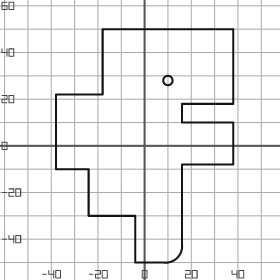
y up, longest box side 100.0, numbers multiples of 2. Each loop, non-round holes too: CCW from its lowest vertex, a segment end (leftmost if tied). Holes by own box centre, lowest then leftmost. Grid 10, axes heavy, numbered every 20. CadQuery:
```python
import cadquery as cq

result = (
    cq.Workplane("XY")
    .moveTo(-4.0, -50.0)
    .lineTo(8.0, -50.0)
    .threePointArc((14.0, -48.0), (16.0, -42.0))
    .lineTo(16.0, -8.0)
    .lineTo(38.0, -8.0)
    .lineTo(38.0, 10.0)
    .lineTo(16.0, 10.0)
    .lineTo(16.0, 18.0)
    .lineTo(38.0, 18.0)
    .lineTo(38.0, 50.0)
    .lineTo(-18.0, 50.0)
    .lineTo(-18.0, 22.0)
    .lineTo(-38.0, 22.0)
    .lineTo(-38.0, -10.0)
    .lineTo(-24.0, -10.0)
    .lineTo(-24.0, -30.0)
    .lineTo(-4.0, -30.0)
    .close()
    .moveTo(10.0, 28.0)
    .circle(2.0)
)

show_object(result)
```